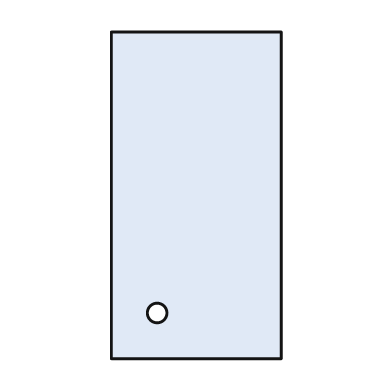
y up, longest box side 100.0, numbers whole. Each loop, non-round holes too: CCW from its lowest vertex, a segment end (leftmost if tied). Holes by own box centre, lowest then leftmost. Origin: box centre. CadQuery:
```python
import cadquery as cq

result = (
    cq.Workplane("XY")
    .moveTo(-26.0, -50.0)
    .lineTo(26.0, -50.0)
    .lineTo(26.0, 50.0)
    .lineTo(-26.0, 50.0)
    .close()
    .moveTo(-12.0, -36.0)
    .circle(3.0)
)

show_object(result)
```